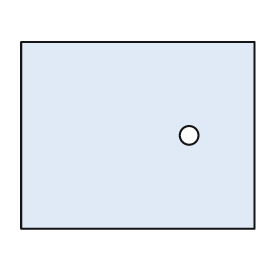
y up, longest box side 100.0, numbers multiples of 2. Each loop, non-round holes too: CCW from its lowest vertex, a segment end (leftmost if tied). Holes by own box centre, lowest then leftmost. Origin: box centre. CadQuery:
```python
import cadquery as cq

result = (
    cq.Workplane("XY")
    .moveTo(-50.0, -40.0)
    .lineTo(50.0, -40.0)
    .lineTo(50.0, 40.0)
    .lineTo(-50.0, 40.0)
    .close()
    .moveTo(22.0, 0.0)
    .circle(4.0)
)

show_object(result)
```